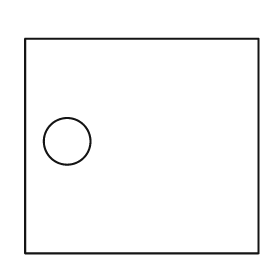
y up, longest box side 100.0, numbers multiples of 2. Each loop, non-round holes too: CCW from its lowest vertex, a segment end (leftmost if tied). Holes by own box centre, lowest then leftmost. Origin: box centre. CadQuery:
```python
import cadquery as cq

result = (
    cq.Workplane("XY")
    .moveTo(-50.0, -46.0)
    .lineTo(50.0, -46.0)
    .lineTo(50.0, 46.0)
    .lineTo(-50.0, 46.0)
    .close()
    .moveTo(-32.0, 2.0)
    .circle(10.0)
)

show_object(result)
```